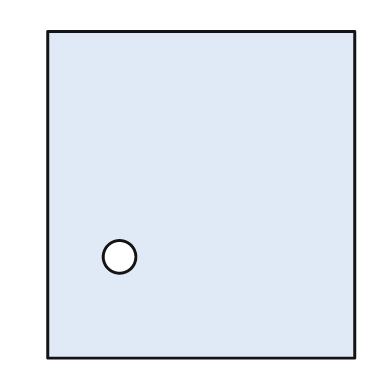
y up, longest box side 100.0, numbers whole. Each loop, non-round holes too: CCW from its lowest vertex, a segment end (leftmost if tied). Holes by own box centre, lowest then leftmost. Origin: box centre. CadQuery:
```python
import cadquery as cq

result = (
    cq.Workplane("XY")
    .moveTo(-47.0, -50.0)
    .lineTo(47.0, -50.0)
    .lineTo(47.0, 50.0)
    .lineTo(-47.0, 50.0)
    .close()
    .moveTo(-25.0, -19.0)
    .circle(5.0)
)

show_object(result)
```